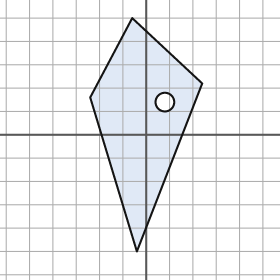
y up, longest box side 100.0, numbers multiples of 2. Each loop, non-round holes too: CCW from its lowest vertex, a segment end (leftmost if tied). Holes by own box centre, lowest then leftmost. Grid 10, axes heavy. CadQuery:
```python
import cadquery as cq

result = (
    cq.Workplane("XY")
    .moveTo(-4.0, -50.0)
    .lineTo(24.0, 22.0)
    .lineTo(-6.0, 50.0)
    .lineTo(-24.0, 16.0)
    .close()
    .moveTo(8.0, 14.0)
    .circle(4.0)
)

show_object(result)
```